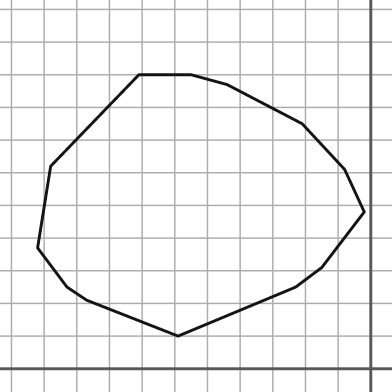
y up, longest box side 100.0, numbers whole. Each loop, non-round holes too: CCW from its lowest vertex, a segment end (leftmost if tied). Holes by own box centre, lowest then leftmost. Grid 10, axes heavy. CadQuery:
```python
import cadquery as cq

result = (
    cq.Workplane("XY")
    .moveTo(-59.0, 10.0)
    .lineTo(-23.0, 25.0)
    .lineTo(-15.0, 31.0)
    .lineTo(-2.0, 48.0)
    .lineTo(-8.0, 61.0)
    .lineTo(-21.0, 75.0)
    .lineTo(-44.0, 87.0)
    .lineTo(-55.0, 90.0)
    .lineTo(-71.0, 90.0)
    .lineTo(-98.0, 62.0)
    .lineTo(-102.0, 37.0)
    .lineTo(-93.0, 25.0)
    .lineTo(-87.0, 21.0)
    .close()
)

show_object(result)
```